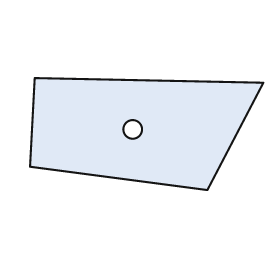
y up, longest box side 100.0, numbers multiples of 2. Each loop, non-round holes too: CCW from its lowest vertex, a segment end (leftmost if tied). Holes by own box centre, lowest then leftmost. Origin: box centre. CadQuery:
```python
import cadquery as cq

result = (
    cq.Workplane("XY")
    .moveTo(26.0, -24.0)
    .lineTo(50.0, 22.0)
    .lineTo(-48.0, 24.0)
    .lineTo(-50.0, -14.0)
    .close()
    .moveTo(-6.0, 2.0)
    .circle(4.0)
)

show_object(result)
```